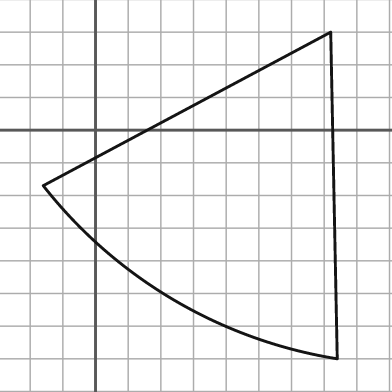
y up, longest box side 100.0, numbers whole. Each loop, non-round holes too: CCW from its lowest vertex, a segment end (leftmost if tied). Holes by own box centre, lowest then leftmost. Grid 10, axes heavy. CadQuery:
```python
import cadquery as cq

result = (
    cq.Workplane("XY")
    .moveTo(74.0, -70.0)
    .lineTo(72.0, 30.0)
    .lineTo(-16.0, -17.0)
    .threePointArc((24.0, -52.0), (74.0, -70.0))
    .close()
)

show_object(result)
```